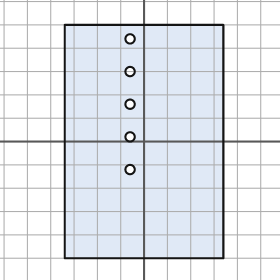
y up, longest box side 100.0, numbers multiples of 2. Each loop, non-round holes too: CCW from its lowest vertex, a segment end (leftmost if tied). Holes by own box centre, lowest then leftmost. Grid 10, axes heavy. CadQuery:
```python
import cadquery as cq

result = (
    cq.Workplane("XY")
    .moveTo(-34.0, -50.0)
    .lineTo(34.0, -50.0)
    .lineTo(34.0, 50.0)
    .lineTo(-34.0, 50.0)
    .close()
    .moveTo(-6.0, -12.0)
    .circle(2.0)
    .moveTo(-6.0, 2.0)
    .circle(2.0)
    .moveTo(-6.0, 16.0)
    .circle(2.0)
    .moveTo(-6.0, 30.0)
    .circle(2.0)
    .moveTo(-6.0, 44.0)
    .circle(2.0)
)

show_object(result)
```